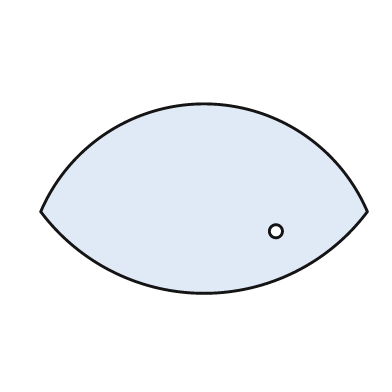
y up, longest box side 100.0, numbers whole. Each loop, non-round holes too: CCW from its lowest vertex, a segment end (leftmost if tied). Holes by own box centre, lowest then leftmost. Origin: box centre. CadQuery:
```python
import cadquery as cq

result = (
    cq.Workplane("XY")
    .moveTo(-50.0, -4.0)
    .threePointArc((0.0, -29.0), (50.0, -4.0))
    .threePointArc((0.0, 29.0), (-50.0, -4.0))
    .close()
    .moveTo(22.0, -10.0)
    .circle(2.0)
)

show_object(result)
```